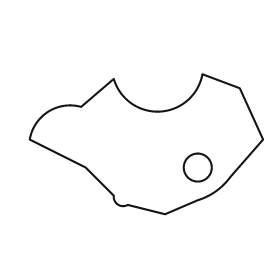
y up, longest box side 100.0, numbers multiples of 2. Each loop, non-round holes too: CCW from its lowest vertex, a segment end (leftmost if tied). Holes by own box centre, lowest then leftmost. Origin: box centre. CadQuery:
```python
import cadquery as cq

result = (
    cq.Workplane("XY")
    .moveTo(8.0, -30.0)
    .lineTo(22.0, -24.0)
    .threePointArc((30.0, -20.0), (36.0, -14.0))
    .lineTo(50.0, 2.0)
    .lineTo(40.0, 24.0)
    .lineTo(24.0, 30.0)
    .threePointArc((6.0, 14.0), (-14.0, 28.0))
    .lineTo(-28.0, 16.0)
    .threePointArc((-42.0, 14.0), (-50.0, 2.0))
    .lineTo(-26.0, -10.0)
    .lineTo(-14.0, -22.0)
    .threePointArc((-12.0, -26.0), (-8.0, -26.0))
    .close()
    .moveTo(22.0, -10.0)
    .circle(6.0)
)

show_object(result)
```